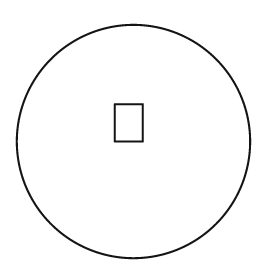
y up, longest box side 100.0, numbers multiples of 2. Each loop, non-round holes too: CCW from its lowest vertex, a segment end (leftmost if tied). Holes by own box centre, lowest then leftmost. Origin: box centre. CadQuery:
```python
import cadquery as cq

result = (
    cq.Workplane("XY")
    .moveTo(0.0, 0.0)
    .circle(50.0)
    .moveTo(-8.0, 0.0)
    .lineTo(4.0, 0.0)
    .lineTo(4.0, 16.0)
    .lineTo(-8.0, 16.0)
    .close()
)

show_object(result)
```